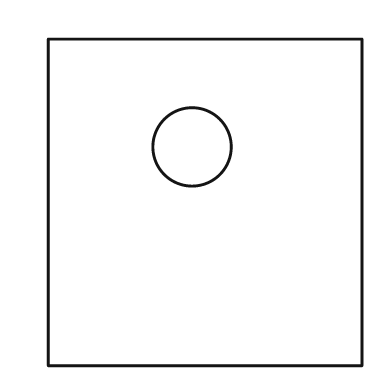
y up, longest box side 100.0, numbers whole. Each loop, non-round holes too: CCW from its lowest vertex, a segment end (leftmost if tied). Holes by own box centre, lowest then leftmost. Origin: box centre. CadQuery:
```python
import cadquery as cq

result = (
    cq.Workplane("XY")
    .moveTo(-48.0, -50.0)
    .lineTo(48.0, -50.0)
    .lineTo(48.0, 50.0)
    .lineTo(-48.0, 50.0)
    .close()
    .moveTo(-4.0, 17.0)
    .circle(12.0)
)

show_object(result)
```